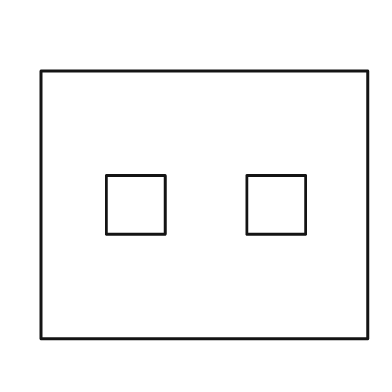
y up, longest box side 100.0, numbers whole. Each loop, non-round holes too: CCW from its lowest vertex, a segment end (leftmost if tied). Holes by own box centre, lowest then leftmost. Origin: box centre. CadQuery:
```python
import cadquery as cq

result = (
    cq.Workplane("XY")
    .moveTo(-50.0, -41.0)
    .lineTo(50.0, -41.0)
    .lineTo(50.0, 41.0)
    .lineTo(-50.0, 41.0)
    .close()
    .moveTo(-30.0, -9.0)
    .lineTo(-12.0, -9.0)
    .lineTo(-12.0, 9.0)
    .lineTo(-30.0, 9.0)
    .close()
    .moveTo(13.0, -9.0)
    .lineTo(31.0, -9.0)
    .lineTo(31.0, 9.0)
    .lineTo(13.0, 9.0)
    .close()
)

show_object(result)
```